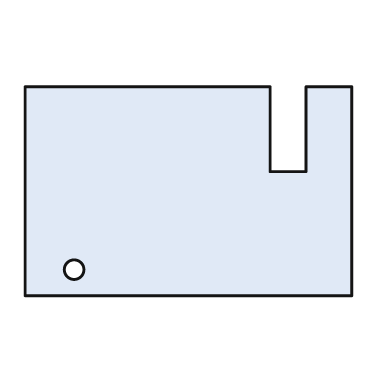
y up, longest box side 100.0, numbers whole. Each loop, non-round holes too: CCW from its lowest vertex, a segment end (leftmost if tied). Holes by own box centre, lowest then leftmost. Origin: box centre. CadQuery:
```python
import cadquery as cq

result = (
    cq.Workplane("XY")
    .moveTo(-50.0, -32.0)
    .lineTo(50.0, -32.0)
    .lineTo(50.0, 32.0)
    .lineTo(36.0, 32.0)
    .lineTo(36.0, 6.0)
    .lineTo(25.0, 6.0)
    .lineTo(25.0, 32.0)
    .lineTo(-50.0, 32.0)
    .close()
    .moveTo(-35.0, -24.0)
    .circle(3.0)
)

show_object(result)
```